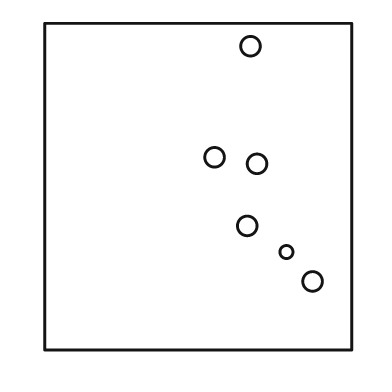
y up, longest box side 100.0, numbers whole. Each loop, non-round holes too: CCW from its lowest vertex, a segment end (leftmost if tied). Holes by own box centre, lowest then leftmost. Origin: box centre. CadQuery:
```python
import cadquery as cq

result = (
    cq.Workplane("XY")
    .moveTo(-47.0, -50.0)
    .lineTo(47.0, -50.0)
    .lineTo(47.0, 50.0)
    .lineTo(-47.0, 50.0)
    .close()
    .moveTo(35.0, -29.0)
    .circle(3.0)
    .moveTo(27.0, -20.0)
    .circle(2.0)
    .moveTo(15.0, -12.0)
    .circle(3.0)
    .moveTo(18.0, 7.0)
    .circle(3.0)
    .moveTo(5.0, 9.0)
    .circle(3.0)
    .moveTo(16.0, 43.0)
    .circle(3.0)
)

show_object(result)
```